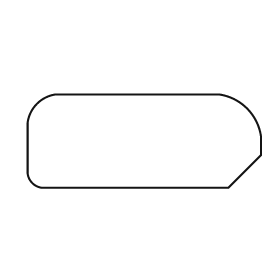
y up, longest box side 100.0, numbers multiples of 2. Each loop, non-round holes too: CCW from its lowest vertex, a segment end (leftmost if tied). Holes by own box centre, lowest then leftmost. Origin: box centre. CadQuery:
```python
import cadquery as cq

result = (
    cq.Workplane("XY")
    .moveTo(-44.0, -20.0)
    .lineTo(36.0, -20.0)
    .lineTo(50.0, -6.0)
    .lineTo(50.0, 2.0)
    .threePointArc((44.0, 14.0), (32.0, 20.0))
    .lineTo(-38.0, 20.0)
    .threePointArc((-46.0, 16.0), (-50.0, 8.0))
    .lineTo(-50.0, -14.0)
    .threePointArc((-48.0, -18.0), (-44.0, -20.0))
    .close()
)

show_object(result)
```